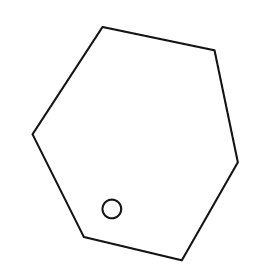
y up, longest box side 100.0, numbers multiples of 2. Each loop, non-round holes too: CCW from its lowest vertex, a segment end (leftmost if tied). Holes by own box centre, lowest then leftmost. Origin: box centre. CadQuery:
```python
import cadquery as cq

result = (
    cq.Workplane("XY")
    .moveTo(20.0, -50.0)
    .lineTo(44.0, -8.0)
    .lineTo(34.0, 40.0)
    .lineTo(-14.0, 50.0)
    .lineTo(-44.0, 4.0)
    .lineTo(-22.0, -40.0)
    .close()
    .moveTo(-10.0, -28.0)
    .circle(4.0)
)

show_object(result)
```